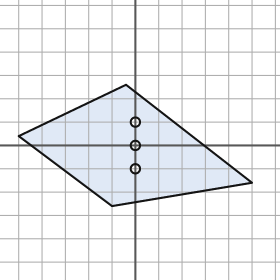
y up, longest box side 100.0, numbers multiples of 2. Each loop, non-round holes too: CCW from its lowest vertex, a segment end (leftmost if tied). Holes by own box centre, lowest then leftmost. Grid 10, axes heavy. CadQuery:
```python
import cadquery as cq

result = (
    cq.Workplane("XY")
    .moveTo(-10.0, -26.0)
    .lineTo(50.0, -16.0)
    .lineTo(-4.0, 26.0)
    .lineTo(-50.0, 4.0)
    .close()
    .moveTo(0.0, -10.0)
    .circle(2.0)
    .moveTo(0.0, 0.0)
    .circle(2.0)
    .moveTo(0.0, 10.0)
    .circle(2.0)
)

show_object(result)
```